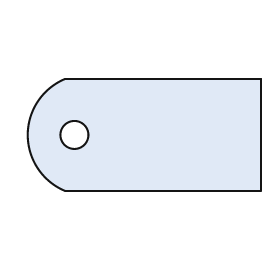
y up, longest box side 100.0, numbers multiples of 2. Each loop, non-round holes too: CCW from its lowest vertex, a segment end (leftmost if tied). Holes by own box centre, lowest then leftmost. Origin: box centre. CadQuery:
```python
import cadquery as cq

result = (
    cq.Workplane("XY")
    .moveTo(-34.0, -24.0)
    .lineTo(50.0, -24.0)
    .lineTo(50.0, 24.0)
    .lineTo(-34.0, 24.0)
    .threePointArc((-50.0, 0.0), (-34.0, -24.0))
    .close()
    .moveTo(-30.0, 0.0)
    .circle(6.0)
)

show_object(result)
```